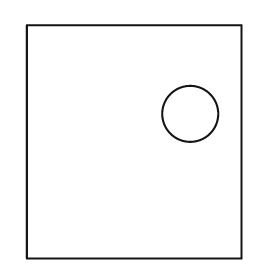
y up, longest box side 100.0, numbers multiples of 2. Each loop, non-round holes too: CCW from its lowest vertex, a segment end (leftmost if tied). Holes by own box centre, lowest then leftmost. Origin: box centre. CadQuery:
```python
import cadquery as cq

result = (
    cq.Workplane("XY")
    .moveTo(-46.0, -50.0)
    .lineTo(46.0, -50.0)
    .lineTo(46.0, 50.0)
    .lineTo(-46.0, 50.0)
    .close()
    .moveTo(24.0, 12.0)
    .circle(12.0)
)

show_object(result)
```